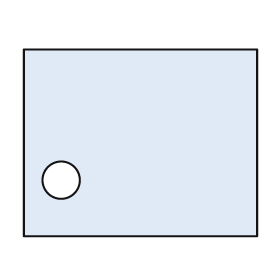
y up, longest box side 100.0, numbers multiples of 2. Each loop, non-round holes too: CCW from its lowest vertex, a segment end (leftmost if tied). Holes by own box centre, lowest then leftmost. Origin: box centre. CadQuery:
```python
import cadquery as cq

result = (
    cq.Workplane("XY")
    .moveTo(-50.0, -40.0)
    .lineTo(50.0, -40.0)
    .lineTo(50.0, 40.0)
    .lineTo(-50.0, 40.0)
    .close()
    .moveTo(-34.0, -16.0)
    .circle(8.0)
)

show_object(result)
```